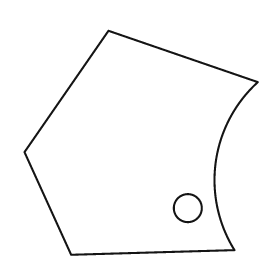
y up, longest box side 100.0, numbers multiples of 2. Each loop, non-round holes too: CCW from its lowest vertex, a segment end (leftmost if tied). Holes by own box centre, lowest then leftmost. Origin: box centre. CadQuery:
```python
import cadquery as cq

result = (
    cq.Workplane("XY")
    .moveTo(-30.0, -48.0)
    .lineTo(40.0, -46.0)
    .threePointArc((32.0, -8.0), (50.0, 26.0))
    .lineTo(-14.0, 48.0)
    .lineTo(-50.0, -4.0)
    .close()
    .moveTo(20.0, -28.0)
    .circle(6.0)
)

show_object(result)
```